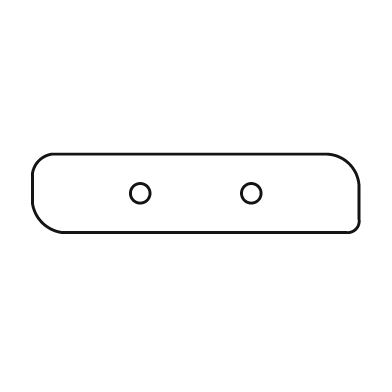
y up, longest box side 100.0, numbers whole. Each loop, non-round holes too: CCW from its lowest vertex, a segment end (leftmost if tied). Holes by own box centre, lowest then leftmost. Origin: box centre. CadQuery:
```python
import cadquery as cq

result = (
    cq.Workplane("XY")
    .moveTo(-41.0, -12.0)
    .lineTo(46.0, -12.0)
    .threePointArc((49.0, -11.0), (50.0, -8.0))
    .lineTo(50.0, 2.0)
    .threePointArc((47.0, 9.0), (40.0, 12.0))
    .lineTo(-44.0, 12.0)
    .threePointArc((-48.0, 10.0), (-50.0, 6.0))
    .lineTo(-50.0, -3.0)
    .threePointArc((-47.0, -9.0), (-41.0, -12.0))
    .close()
    .moveTo(-17.0, 0.0)
    .circle(3.0)
    .moveTo(17.0, 0.0)
    .circle(3.0)
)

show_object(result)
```